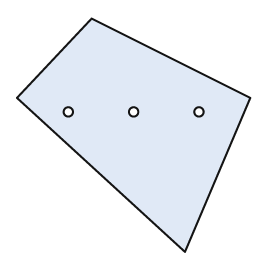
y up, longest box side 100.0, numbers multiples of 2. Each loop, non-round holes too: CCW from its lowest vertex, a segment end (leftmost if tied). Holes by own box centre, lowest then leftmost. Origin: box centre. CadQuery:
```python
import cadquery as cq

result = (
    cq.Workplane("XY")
    .moveTo(22.0, -50.0)
    .lineTo(50.0, 16.0)
    .lineTo(-18.0, 50.0)
    .lineTo(-50.0, 16.0)
    .close()
    .moveTo(-28.0, 10.0)
    .circle(2.0)
    .moveTo(0.0, 10.0)
    .circle(2.0)
    .moveTo(28.0, 10.0)
    .circle(2.0)
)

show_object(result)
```